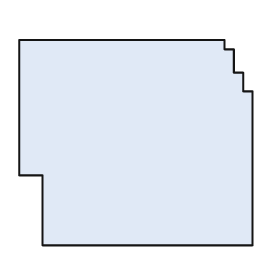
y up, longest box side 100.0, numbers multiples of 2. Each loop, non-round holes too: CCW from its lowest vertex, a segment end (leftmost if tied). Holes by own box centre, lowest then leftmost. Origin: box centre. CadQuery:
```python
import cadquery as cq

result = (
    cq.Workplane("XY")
    .moveTo(-40.0, -44.0)
    .lineTo(50.0, -44.0)
    .lineTo(50.0, 22.0)
    .lineTo(46.0, 22.0)
    .lineTo(46.0, 30.0)
    .lineTo(42.0, 30.0)
    .lineTo(42.0, 40.0)
    .lineTo(38.0, 40.0)
    .lineTo(38.0, 44.0)
    .lineTo(-50.0, 44.0)
    .lineTo(-50.0, -14.0)
    .lineTo(-40.0, -14.0)
    .close()
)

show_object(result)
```